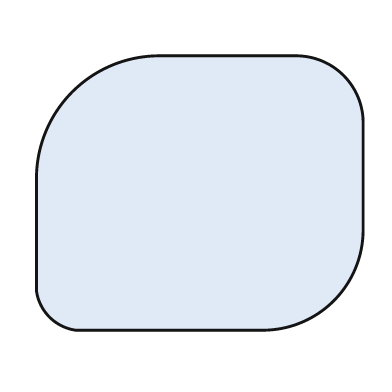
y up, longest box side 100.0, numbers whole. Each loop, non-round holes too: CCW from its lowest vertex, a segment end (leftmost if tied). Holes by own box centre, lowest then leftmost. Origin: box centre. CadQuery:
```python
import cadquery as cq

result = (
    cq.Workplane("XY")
    .moveTo(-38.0, -42.0)
    .lineTo(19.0, -42.0)
    .threePointArc((41.0, -33.0), (50.0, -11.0))
    .lineTo(50.0, 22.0)
    .threePointArc((44.0, 36.0), (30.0, 42.0))
    .lineTo(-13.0, 42.0)
    .threePointArc((-39.0, 31.0), (-50.0, 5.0))
    .lineTo(-50.0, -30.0)
    .threePointArc((-46.0, -38.0), (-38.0, -42.0))
    .close()
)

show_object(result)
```